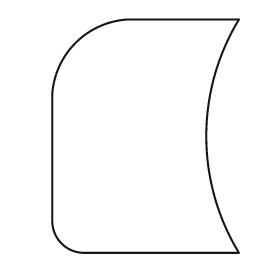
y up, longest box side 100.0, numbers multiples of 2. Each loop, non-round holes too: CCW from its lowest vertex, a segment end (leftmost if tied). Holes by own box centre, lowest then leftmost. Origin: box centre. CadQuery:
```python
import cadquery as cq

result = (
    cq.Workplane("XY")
    .moveTo(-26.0, -50.0)
    .lineTo(40.0, -50.0)
    .threePointArc((26.0, 0.0), (40.0, 50.0))
    .lineTo(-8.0, 50.0)
    .threePointArc((-30.0, 40.0), (-40.0, 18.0))
    .lineTo(-40.0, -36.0)
    .threePointArc((-36.0, -46.0), (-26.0, -50.0))
    .close()
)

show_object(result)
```